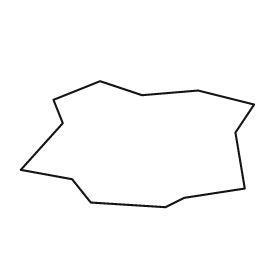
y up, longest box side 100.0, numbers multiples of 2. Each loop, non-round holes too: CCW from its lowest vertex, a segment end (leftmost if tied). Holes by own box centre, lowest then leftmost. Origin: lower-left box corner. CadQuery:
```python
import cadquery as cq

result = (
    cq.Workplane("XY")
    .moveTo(62.0, 0.0)
    .lineTo(70.0, 4.0)
    .lineTo(96.0, 8.0)
    .lineTo(92.0, 32.0)
    .lineTo(100.0, 44.0)
    .lineTo(76.0, 50.0)
    .lineTo(52.0, 48.0)
    .lineTo(34.0, 54.0)
    .lineTo(14.0, 46.0)
    .lineTo(18.0, 36.0)
    .lineTo(0.0, 16.0)
    .lineTo(22.0, 12.0)
    .lineTo(30.0, 2.0)
    .close()
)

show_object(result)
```